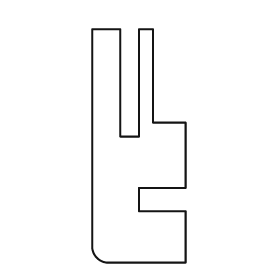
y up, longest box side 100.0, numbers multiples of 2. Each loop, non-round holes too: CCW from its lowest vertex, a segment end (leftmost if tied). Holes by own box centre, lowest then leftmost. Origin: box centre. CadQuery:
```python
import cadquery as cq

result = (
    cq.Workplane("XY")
    .moveTo(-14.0, -50.0)
    .lineTo(20.0, -50.0)
    .lineTo(20.0, -28.0)
    .lineTo(0.0, -28.0)
    .lineTo(0.0, -18.0)
    .lineTo(20.0, -18.0)
    .lineTo(20.0, 10.0)
    .lineTo(6.0, 10.0)
    .lineTo(6.0, 50.0)
    .lineTo(0.0, 50.0)
    .lineTo(0.0, 4.0)
    .lineTo(-8.0, 4.0)
    .lineTo(-8.0, 50.0)
    .lineTo(-20.0, 50.0)
    .lineTo(-20.0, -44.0)
    .threePointArc((-18.0, -48.0), (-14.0, -50.0))
    .close()
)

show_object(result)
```